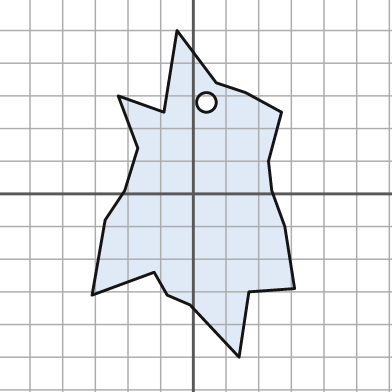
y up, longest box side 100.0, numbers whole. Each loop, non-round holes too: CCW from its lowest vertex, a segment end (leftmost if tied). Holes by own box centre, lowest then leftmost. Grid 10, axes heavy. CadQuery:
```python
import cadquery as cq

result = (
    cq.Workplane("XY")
    .moveTo(14.0, -50.0)
    .lineTo(17.0, -30.0)
    .lineTo(31.0, -29.0)
    .lineTo(28.0, -10.0)
    .lineTo(24.0, 1.0)
    .lineTo(23.0, 10.0)
    .lineTo(27.0, 25.0)
    .lineTo(16.0, 31.0)
    .lineTo(7.0, 34.0)
    .lineTo(-5.0, 50.0)
    .lineTo(-9.0, 25.0)
    .lineTo(-23.0, 30.0)
    .lineTo(-17.0, 14.0)
    .lineTo(-21.0, 1.0)
    .lineTo(-27.0, -8.0)
    .lineTo(-31.0, -31.0)
    .lineTo(-12.0, -24.0)
    .lineTo(-8.0, -31.0)
    .lineTo(-1.0, -34.0)
    .close()
    .moveTo(4.0, 28.0)
    .circle(3.0)
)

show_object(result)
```